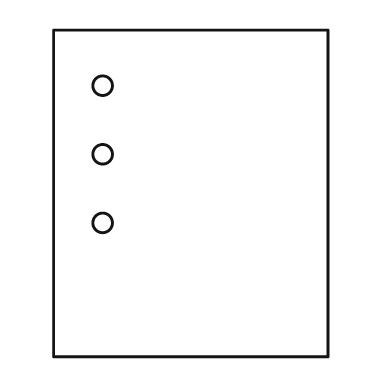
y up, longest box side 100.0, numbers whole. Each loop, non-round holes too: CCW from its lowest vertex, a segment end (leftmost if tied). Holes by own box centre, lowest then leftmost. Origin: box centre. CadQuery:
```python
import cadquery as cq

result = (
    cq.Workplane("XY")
    .moveTo(-42.0, -50.0)
    .lineTo(42.0, -50.0)
    .lineTo(42.0, 50.0)
    .lineTo(-42.0, 50.0)
    .close()
    .moveTo(-27.0, -9.0)
    .circle(3.0)
    .moveTo(-27.0, 12.0)
    .circle(3.0)
    .moveTo(-27.0, 33.0)
    .circle(3.0)
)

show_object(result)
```